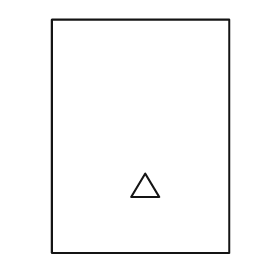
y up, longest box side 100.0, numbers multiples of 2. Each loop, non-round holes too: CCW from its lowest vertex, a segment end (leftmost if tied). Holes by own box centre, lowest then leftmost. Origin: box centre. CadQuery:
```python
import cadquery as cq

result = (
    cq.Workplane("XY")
    .moveTo(-38.0, -50.0)
    .lineTo(38.0, -50.0)
    .lineTo(38.0, 50.0)
    .lineTo(-38.0, 50.0)
    .close()
    .moveTo(-4.0, -26.0)
    .lineTo(8.0, -26.0)
    .lineTo(2.0, -16.0)
    .close()
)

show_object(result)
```